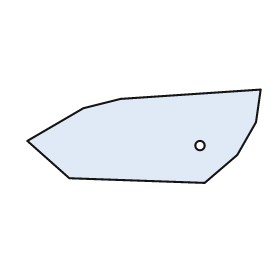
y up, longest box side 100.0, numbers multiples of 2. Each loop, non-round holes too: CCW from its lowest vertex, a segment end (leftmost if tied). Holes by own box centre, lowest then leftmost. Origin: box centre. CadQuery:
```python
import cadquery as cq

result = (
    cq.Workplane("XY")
    .moveTo(26.0, -20.0)
    .lineTo(40.0, -8.0)
    .lineTo(48.0, 6.0)
    .lineTo(50.0, 20.0)
    .lineTo(-10.0, 16.0)
    .lineTo(-26.0, 12.0)
    .lineTo(-50.0, -2.0)
    .lineTo(-32.0, -18.0)
    .close()
    .moveTo(24.0, -4.0)
    .circle(2.0)
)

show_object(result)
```